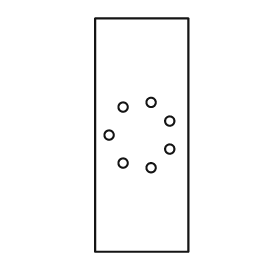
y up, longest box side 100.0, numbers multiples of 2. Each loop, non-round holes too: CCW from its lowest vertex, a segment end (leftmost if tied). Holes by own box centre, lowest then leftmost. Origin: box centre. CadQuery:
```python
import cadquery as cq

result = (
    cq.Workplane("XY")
    .moveTo(-20.0, -50.0)
    .lineTo(20.0, -50.0)
    .lineTo(20.0, 50.0)
    .lineTo(-20.0, 50.0)
    .close()
    .moveTo(4.0, -14.0)
    .circle(2.0)
    .moveTo(-8.0, -12.0)
    .circle(2.0)
    .moveTo(12.0, -6.0)
    .circle(2.0)
    .moveTo(-14.0, 0.0)
    .circle(2.0)
    .moveTo(12.0, 6.0)
    .circle(2.0)
    .moveTo(-8.0, 12.0)
    .circle(2.0)
    .moveTo(4.0, 14.0)
    .circle(2.0)
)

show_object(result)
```